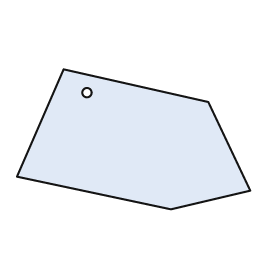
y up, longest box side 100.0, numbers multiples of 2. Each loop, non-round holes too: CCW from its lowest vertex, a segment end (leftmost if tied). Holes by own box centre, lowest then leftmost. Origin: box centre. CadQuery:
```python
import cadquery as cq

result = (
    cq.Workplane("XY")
    .moveTo(16.0, -30.0)
    .lineTo(50.0, -22.0)
    .lineTo(32.0, 16.0)
    .lineTo(-30.0, 30.0)
    .lineTo(-50.0, -16.0)
    .close()
    .moveTo(-20.0, 20.0)
    .circle(2.0)
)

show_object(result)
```